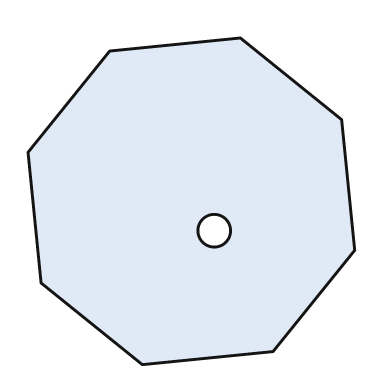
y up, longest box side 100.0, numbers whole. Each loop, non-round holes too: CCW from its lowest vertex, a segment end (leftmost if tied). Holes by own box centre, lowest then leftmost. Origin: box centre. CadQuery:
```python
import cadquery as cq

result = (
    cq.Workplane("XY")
    .moveTo(-15.0, -50.0)
    .lineTo(25.0, -46.0)
    .lineTo(50.0, -15.0)
    .lineTo(46.0, 25.0)
    .lineTo(15.0, 50.0)
    .lineTo(-25.0, 46.0)
    .lineTo(-50.0, 15.0)
    .lineTo(-46.0, -25.0)
    .close()
    .moveTo(7.0, -9.0)
    .circle(5.0)
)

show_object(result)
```